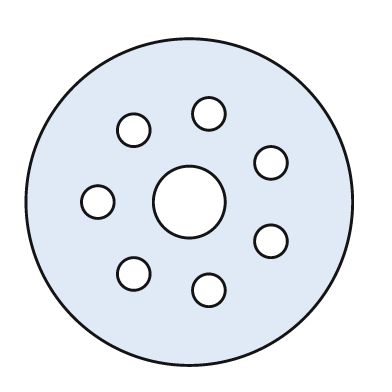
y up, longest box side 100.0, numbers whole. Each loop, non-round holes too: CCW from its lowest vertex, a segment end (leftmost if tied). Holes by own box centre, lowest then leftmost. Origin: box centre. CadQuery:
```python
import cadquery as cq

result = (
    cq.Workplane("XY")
    .moveTo(0.0, 0.0)
    .circle(50.0)
    .moveTo(6.0, -27.0)
    .circle(5.0)
    .moveTo(-17.0, -22.0)
    .circle(5.0)
    .moveTo(25.0, -12.0)
    .circle(5.0)
    .moveTo(-28.0, 0.0)
    .circle(5.0)
    .moveTo(0.0, 0.0)
    .circle(11.0)
    .moveTo(25.0, 12.0)
    .circle(5.0)
    .moveTo(-17.0, 22.0)
    .circle(5.0)
    .moveTo(6.0, 27.0)
    .circle(5.0)
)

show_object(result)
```